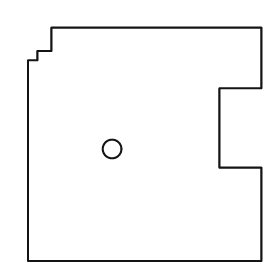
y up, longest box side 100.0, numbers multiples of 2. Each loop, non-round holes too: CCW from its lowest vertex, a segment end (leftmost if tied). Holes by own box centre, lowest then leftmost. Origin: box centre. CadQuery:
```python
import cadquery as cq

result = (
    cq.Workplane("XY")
    .moveTo(-50.0, -50.0)
    .lineTo(50.0, -50.0)
    .lineTo(50.0, -10.0)
    .lineTo(32.0, -10.0)
    .lineTo(32.0, 24.0)
    .lineTo(50.0, 24.0)
    .lineTo(50.0, 50.0)
    .lineTo(-40.0, 50.0)
    .lineTo(-40.0, 40.0)
    .lineTo(-46.0, 40.0)
    .lineTo(-46.0, 36.0)
    .lineTo(-50.0, 36.0)
    .close()
    .moveTo(-14.0, -2.0)
    .circle(4.0)
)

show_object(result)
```